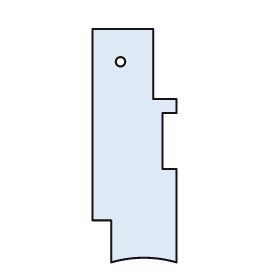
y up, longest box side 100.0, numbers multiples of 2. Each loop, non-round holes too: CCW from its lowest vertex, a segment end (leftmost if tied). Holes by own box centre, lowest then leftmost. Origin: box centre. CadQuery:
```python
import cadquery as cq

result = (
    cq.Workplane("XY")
    .moveTo(-10.0, -50.0)
    .threePointArc((4.0, -48.0), (18.0, -50.0))
    .lineTo(18.0, -10.0)
    .lineTo(12.0, -10.0)
    .lineTo(12.0, 14.0)
    .lineTo(18.0, 14.0)
    .lineTo(18.0, 20.0)
    .lineTo(8.0, 20.0)
    .lineTo(8.0, 50.0)
    .lineTo(-18.0, 50.0)
    .lineTo(-18.0, -32.0)
    .lineTo(-10.0, -32.0)
    .close()
    .moveTo(-6.0, 36.0)
    .circle(2.0)
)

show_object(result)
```